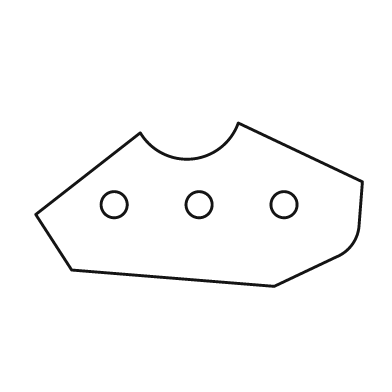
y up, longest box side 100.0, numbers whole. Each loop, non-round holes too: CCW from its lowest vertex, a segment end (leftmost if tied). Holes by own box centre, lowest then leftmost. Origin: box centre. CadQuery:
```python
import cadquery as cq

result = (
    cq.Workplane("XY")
    .moveTo(23.0, -25.0)
    .lineTo(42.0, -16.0)
    .threePointArc((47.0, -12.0), (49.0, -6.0))
    .lineTo(50.0, 7.0)
    .lineTo(12.0, 25.0)
    .threePointArc((-2.0, 14.0), (-18.0, 22.0))
    .lineTo(-50.0, -3.0)
    .lineTo(-39.0, -20.0)
    .close()
    .moveTo(-26.0, 0.0)
    .circle(4.0)
    .moveTo(0.0, 0.0)
    .circle(4.0)
    .moveTo(26.0, 0.0)
    .circle(4.0)
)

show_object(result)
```